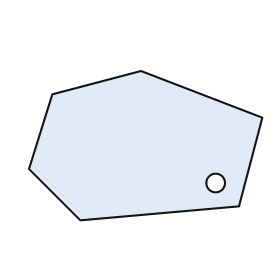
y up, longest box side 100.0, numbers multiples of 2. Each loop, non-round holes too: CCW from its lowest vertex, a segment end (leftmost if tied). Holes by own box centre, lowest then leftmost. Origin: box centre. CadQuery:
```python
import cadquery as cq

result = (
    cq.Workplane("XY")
    .moveTo(-28.0, -32.0)
    .lineTo(40.0, -26.0)
    .lineTo(50.0, 12.0)
    .lineTo(-2.0, 32.0)
    .lineTo(-40.0, 22.0)
    .lineTo(-50.0, -10.0)
    .close()
    .moveTo(30.0, -16.0)
    .circle(4.0)
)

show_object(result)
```